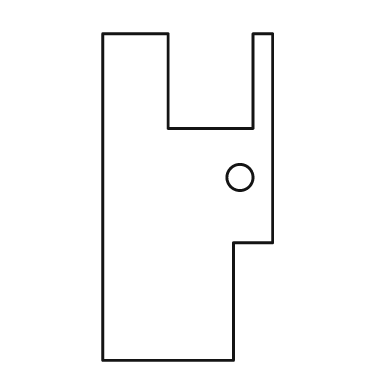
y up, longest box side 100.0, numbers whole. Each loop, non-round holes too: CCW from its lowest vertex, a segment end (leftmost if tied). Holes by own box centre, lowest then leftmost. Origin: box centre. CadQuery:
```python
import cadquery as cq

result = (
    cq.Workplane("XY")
    .moveTo(-26.0, -50.0)
    .lineTo(14.0, -50.0)
    .lineTo(14.0, -14.0)
    .lineTo(26.0, -14.0)
    .lineTo(26.0, 50.0)
    .lineTo(20.0, 50.0)
    .lineTo(20.0, 21.0)
    .lineTo(-6.0, 21.0)
    .lineTo(-6.0, 50.0)
    .lineTo(-26.0, 50.0)
    .close()
    .moveTo(16.0, 6.0)
    .circle(4.0)
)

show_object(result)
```